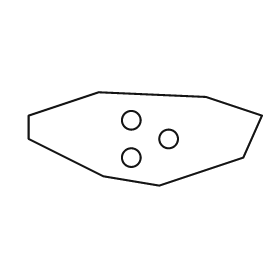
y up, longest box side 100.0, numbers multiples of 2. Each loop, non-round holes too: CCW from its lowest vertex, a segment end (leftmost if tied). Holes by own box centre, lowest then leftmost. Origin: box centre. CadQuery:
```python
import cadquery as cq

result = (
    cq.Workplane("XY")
    .moveTo(6.0, -20.0)
    .lineTo(42.0, -8.0)
    .lineTo(50.0, 10.0)
    .lineTo(26.0, 18.0)
    .lineTo(-20.0, 20.0)
    .lineTo(-50.0, 10.0)
    .lineTo(-50.0, 0.0)
    .lineTo(-18.0, -16.0)
    .close()
    .moveTo(-6.0, -8.0)
    .circle(4.0)
    .moveTo(10.0, 0.0)
    .circle(4.0)
    .moveTo(-6.0, 8.0)
    .circle(4.0)
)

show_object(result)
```